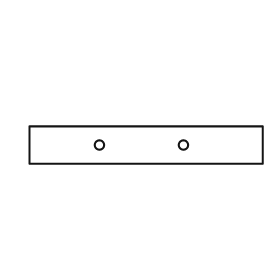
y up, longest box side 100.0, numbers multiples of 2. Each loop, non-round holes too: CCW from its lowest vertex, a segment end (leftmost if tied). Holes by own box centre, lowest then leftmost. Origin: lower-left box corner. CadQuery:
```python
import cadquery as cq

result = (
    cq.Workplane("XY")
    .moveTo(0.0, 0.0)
    .lineTo(100.0, 0.0)
    .lineTo(100.0, 16.0)
    .lineTo(0.0, 16.0)
    .close()
    .moveTo(30.0, 8.0)
    .circle(2.0)
    .moveTo(66.0, 8.0)
    .circle(2.0)
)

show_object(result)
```